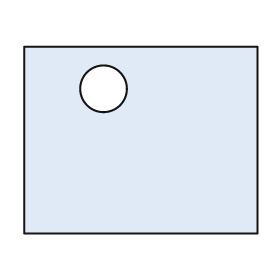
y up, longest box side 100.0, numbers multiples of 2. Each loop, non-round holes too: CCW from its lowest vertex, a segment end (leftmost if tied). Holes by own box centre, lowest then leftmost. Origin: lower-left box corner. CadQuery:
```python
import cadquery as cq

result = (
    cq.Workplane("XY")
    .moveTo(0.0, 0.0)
    .lineTo(100.0, 0.0)
    .lineTo(100.0, 80.0)
    .lineTo(0.0, 80.0)
    .close()
    .moveTo(34.0, 62.0)
    .circle(10.0)
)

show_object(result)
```